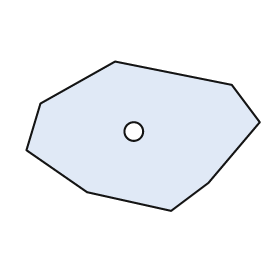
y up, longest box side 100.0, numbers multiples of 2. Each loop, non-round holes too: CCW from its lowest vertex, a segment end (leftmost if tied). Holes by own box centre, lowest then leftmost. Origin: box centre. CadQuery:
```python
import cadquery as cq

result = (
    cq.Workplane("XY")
    .moveTo(12.0, -32.0)
    .lineTo(28.0, -20.0)
    .lineTo(50.0, 6.0)
    .lineTo(38.0, 22.0)
    .lineTo(-12.0, 32.0)
    .lineTo(-44.0, 14.0)
    .lineTo(-50.0, -6.0)
    .lineTo(-24.0, -24.0)
    .close()
    .moveTo(-4.0, 2.0)
    .circle(4.0)
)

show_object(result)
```